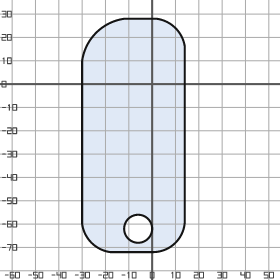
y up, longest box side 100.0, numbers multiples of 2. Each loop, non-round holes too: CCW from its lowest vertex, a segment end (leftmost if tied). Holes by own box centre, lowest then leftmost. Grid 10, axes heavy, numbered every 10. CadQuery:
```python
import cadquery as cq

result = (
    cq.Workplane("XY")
    .moveTo(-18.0, -72.0)
    .lineTo(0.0, -72.0)
    .threePointArc((10.0, -68.0), (14.0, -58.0))
    .lineTo(14.0, 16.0)
    .threePointArc((10.0, 24.0), (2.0, 28.0))
    .lineTo(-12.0, 28.0)
    .threePointArc((-24.0, 22.0), (-30.0, 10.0))
    .lineTo(-30.0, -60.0)
    .threePointArc((-26.0, -68.0), (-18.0, -72.0))
    .close()
    .moveTo(-6.0, -62.0)
    .circle(6.0)
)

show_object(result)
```